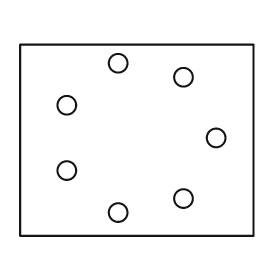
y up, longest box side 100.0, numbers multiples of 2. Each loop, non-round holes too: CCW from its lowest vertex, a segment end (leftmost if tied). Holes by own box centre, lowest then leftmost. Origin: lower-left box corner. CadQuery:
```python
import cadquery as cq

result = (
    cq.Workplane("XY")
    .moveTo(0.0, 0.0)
    .lineTo(100.0, 0.0)
    .lineTo(100.0, 82.0)
    .lineTo(0.0, 82.0)
    .close()
    .moveTo(42.0, 10.0)
    .circle(4.0)
    .moveTo(70.0, 16.0)
    .circle(4.0)
    .moveTo(20.0, 28.0)
    .circle(4.0)
    .moveTo(84.0, 42.0)
    .circle(4.0)
    .moveTo(20.0, 56.0)
    .circle(4.0)
    .moveTo(70.0, 68.0)
    .circle(4.0)
    .moveTo(42.0, 74.0)
    .circle(4.0)
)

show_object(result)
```